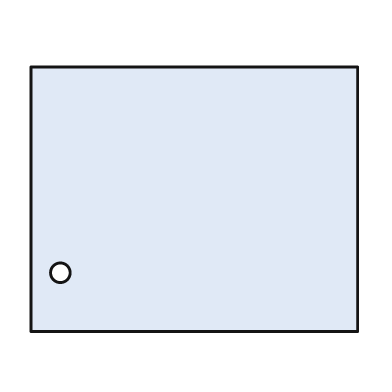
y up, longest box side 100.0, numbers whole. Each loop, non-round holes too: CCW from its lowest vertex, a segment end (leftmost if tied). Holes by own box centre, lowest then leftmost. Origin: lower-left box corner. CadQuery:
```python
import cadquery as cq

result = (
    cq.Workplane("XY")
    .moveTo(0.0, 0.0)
    .lineTo(100.0, 0.0)
    .lineTo(100.0, 81.0)
    .lineTo(0.0, 81.0)
    .close()
    .moveTo(9.0, 18.0)
    .circle(3.0)
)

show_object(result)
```